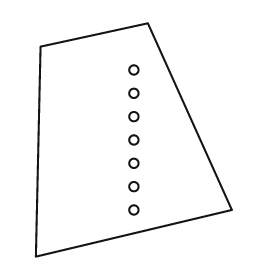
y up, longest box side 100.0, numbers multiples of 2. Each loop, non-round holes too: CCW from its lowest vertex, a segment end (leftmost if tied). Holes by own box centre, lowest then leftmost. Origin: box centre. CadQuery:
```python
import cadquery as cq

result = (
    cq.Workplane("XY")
    .moveTo(-42.0, -50.0)
    .lineTo(42.0, -30.0)
    .lineTo(6.0, 50.0)
    .lineTo(-40.0, 40.0)
    .close()
    .moveTo(0.0, -30.0)
    .circle(2.0)
    .moveTo(0.0, -20.0)
    .circle(2.0)
    .moveTo(0.0, -10.0)
    .circle(2.0)
    .moveTo(0.0, 0.0)
    .circle(2.0)
    .moveTo(0.0, 10.0)
    .circle(2.0)
    .moveTo(0.0, 20.0)
    .circle(2.0)
    .moveTo(0.0, 30.0)
    .circle(2.0)
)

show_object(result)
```